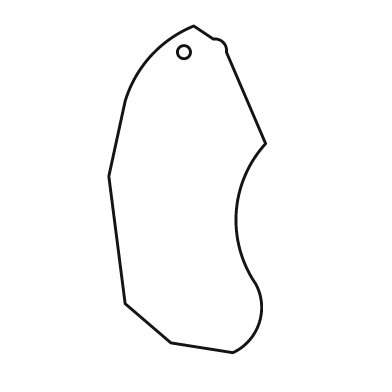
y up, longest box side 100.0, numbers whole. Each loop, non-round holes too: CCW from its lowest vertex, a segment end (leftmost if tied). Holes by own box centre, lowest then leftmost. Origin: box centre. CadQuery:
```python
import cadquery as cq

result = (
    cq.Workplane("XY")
    .moveTo(14.0, -50.0)
    .threePointArc((22.0, -41.0), (21.0, -29.0))
    .threePointArc((15.0, -7.0), (24.0, 14.0))
    .lineTo(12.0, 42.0)
    .threePointArc((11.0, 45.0), (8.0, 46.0))
    .lineTo(2.0, 50.0)
    .threePointArc((-11.0, 41.0), (-19.0, 27.0))
    .lineTo(-24.0, 4.0)
    .lineTo(-19.0, -35.0)
    .lineTo(-5.0, -47.0)
    .close()
    .moveTo(-1.0, 42.0)
    .circle(2.0)
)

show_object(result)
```